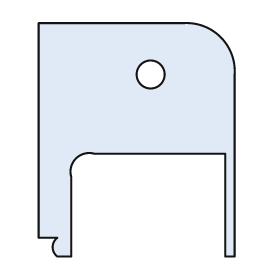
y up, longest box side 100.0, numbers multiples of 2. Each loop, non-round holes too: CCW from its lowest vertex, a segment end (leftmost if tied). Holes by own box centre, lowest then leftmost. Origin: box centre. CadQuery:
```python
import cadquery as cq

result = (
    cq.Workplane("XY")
    .moveTo(-34.0, -50.0)
    .lineTo(-28.0, -50.0)
    .lineTo(-28.0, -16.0)
    .threePointArc((-26.0, -8.0), (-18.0, -6.0))
    .lineTo(38.0, -6.0)
    .lineTo(38.0, -50.0)
    .lineTo(42.0, -50.0)
    .lineTo(42.0, 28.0)
    .threePointArc((36.0, 44.0), (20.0, 50.0))
    .lineTo(-42.0, 50.0)
    .lineTo(-42.0, -42.0)
    .lineTo(-34.0, -42.0)
    .threePointArc((-36.0, -46.0), (-34.0, -50.0))
    .close()
    .moveTo(6.0, 28.0)
    .circle(6.0)
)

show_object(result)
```